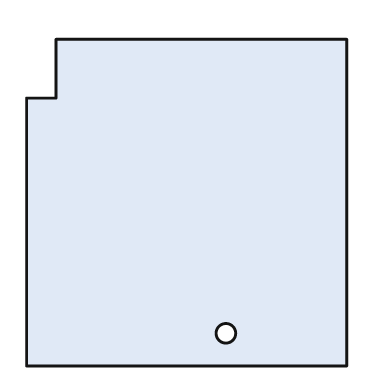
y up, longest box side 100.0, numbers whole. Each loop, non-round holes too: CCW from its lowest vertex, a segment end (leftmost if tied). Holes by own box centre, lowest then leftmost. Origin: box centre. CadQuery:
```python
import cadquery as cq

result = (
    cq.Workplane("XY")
    .moveTo(-49.0, -50.0)
    .lineTo(49.0, -50.0)
    .lineTo(49.0, 50.0)
    .lineTo(-40.0, 50.0)
    .lineTo(-40.0, 32.0)
    .lineTo(-49.0, 32.0)
    .close()
    .moveTo(12.0, -40.0)
    .circle(3.0)
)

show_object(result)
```